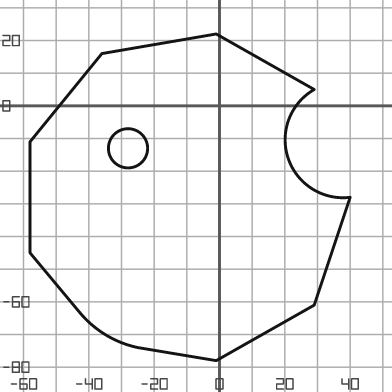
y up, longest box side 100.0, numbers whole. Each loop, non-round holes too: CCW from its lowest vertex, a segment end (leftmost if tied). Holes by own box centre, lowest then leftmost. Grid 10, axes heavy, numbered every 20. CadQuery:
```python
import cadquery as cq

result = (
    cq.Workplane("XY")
    .moveTo(-1.0, -78.0)
    .lineTo(29.0, -61.0)
    .lineTo(40.0, -28.0)
    .threePointArc((21.0, -16.0), (29.0, 5.0))
    .lineTo(-1.0, 22.0)
    .lineTo(-36.0, 16.0)
    .lineTo(-58.0, -11.0)
    .lineTo(-58.0, -45.0)
    .lineTo(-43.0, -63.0)
    .threePointArc((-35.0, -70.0), (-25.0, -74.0))
    .close()
    .moveTo(-28.0, -13.0)
    .circle(6.0)
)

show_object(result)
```